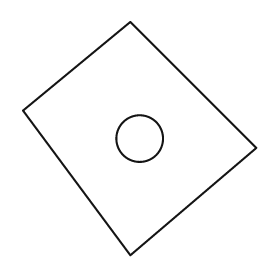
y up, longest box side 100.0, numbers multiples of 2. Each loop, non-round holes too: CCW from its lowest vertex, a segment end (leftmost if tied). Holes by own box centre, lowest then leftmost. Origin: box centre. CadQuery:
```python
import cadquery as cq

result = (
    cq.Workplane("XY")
    .moveTo(-4.0, -50.0)
    .lineTo(50.0, -4.0)
    .lineTo(-4.0, 50.0)
    .lineTo(-50.0, 12.0)
    .close()
    .moveTo(0.0, 0.0)
    .circle(10.0)
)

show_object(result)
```